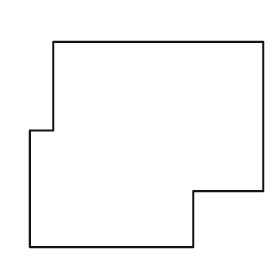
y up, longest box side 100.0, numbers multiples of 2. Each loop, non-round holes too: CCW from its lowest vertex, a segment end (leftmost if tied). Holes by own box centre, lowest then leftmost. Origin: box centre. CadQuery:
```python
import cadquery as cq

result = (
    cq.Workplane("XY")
    .moveTo(-50.0, -44.0)
    .lineTo(20.0, -44.0)
    .lineTo(20.0, -20.0)
    .lineTo(50.0, -20.0)
    .lineTo(50.0, 44.0)
    .lineTo(-40.0, 44.0)
    .lineTo(-40.0, 6.0)
    .lineTo(-50.0, 6.0)
    .close()
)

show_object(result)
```